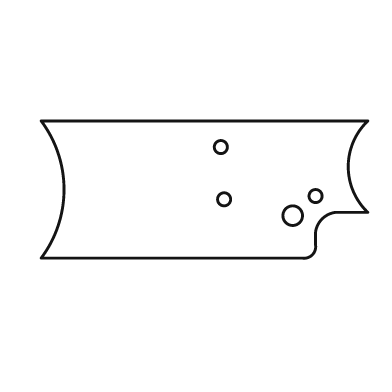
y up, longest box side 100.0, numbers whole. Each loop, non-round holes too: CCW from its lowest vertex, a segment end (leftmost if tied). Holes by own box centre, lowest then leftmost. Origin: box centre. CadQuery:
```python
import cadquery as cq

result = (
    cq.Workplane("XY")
    .moveTo(-50.0, -21.0)
    .lineTo(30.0, -21.0)
    .threePointArc((33.0, -20.0), (34.0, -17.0))
    .lineTo(34.0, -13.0)
    .threePointArc((36.0, -9.0), (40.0, -7.0))
    .lineTo(50.0, -7.0)
    .threePointArc((44.0, 7.0), (50.0, 21.0))
    .lineTo(-50.0, 21.0)
    .threePointArc((-43.0, 0.0), (-50.0, -21.0))
    .close()
    .moveTo(27.0, -8.0)
    .circle(3.0)
    .moveTo(6.0, -3.0)
    .circle(2.0)
    .moveTo(34.0, -2.0)
    .circle(2.0)
    .moveTo(5.0, 13.0)
    .circle(2.0)
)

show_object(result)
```